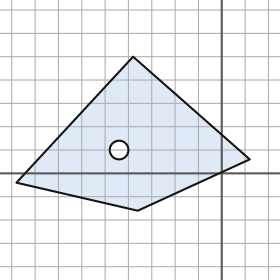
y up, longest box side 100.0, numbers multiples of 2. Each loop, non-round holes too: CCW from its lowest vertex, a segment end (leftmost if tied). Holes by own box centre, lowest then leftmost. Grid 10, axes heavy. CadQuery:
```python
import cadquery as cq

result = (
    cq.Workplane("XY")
    .moveTo(-36.0, -16.0)
    .lineTo(12.0, 6.0)
    .lineTo(-38.0, 50.0)
    .lineTo(-88.0, -4.0)
    .close()
    .moveTo(-44.0, 10.0)
    .circle(4.0)
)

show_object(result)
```